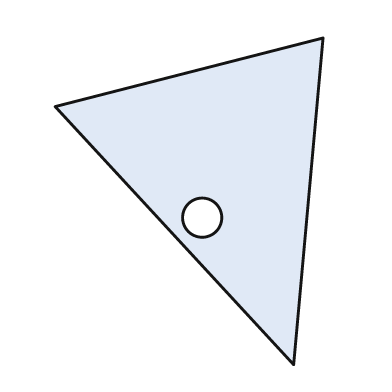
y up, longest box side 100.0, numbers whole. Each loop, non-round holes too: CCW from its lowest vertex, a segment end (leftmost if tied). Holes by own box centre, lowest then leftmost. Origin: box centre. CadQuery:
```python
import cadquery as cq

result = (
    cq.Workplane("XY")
    .moveTo(32.0, -50.0)
    .lineTo(41.0, 50.0)
    .lineTo(-41.0, 29.0)
    .close()
    .moveTo(4.0, -5.0)
    .circle(6.0)
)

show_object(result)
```